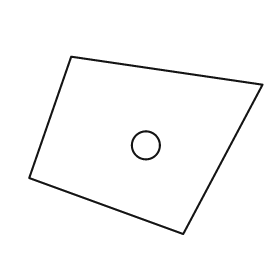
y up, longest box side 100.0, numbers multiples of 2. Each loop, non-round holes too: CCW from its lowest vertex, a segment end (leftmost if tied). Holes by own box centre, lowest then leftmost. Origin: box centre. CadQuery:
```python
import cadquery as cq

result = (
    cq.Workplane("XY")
    .moveTo(16.0, -38.0)
    .lineTo(50.0, 26.0)
    .lineTo(-32.0, 38.0)
    .lineTo(-50.0, -14.0)
    .close()
    .moveTo(0.0, 0.0)
    .circle(6.0)
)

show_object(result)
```